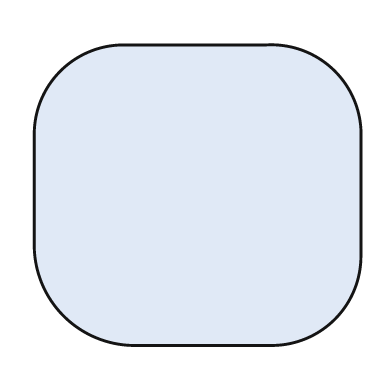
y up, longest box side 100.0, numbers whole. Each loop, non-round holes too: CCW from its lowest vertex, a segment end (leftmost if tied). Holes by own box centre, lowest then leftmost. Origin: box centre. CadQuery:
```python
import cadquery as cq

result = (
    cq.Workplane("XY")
    .moveTo(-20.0, -46.0)
    .lineTo(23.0, -46.0)
    .threePointArc((42.0, -38.0), (50.0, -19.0))
    .lineTo(50.0, 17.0)
    .threePointArc((42.0, 38.0), (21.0, 46.0))
    .lineTo(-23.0, 46.0)
    .threePointArc((-42.0, 38.0), (-50.0, 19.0))
    .lineTo(-50.0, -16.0)
    .threePointArc((-41.0, -37.0), (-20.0, -46.0))
    .close()
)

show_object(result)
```